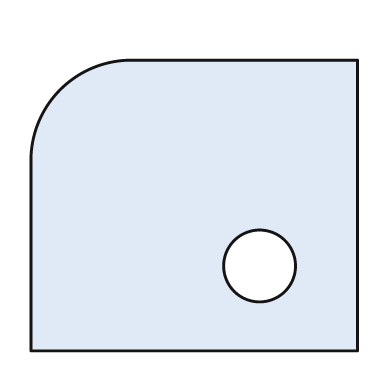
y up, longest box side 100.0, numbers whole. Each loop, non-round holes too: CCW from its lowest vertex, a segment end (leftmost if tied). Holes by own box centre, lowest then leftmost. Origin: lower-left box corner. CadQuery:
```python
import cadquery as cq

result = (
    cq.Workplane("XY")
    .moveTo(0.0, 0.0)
    .lineTo(100.0, 0.0)
    .lineTo(100.0, 89.0)
    .lineTo(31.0, 89.0)
    .threePointArc((9.0, 80.0), (0.0, 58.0))
    .close()
    .moveTo(70.0, 26.0)
    .circle(11.0)
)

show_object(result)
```